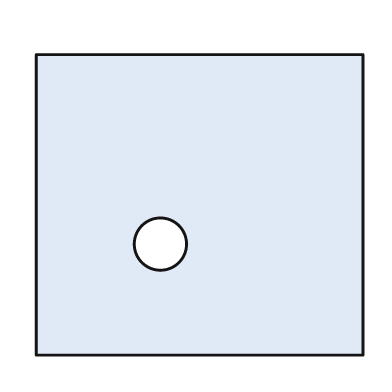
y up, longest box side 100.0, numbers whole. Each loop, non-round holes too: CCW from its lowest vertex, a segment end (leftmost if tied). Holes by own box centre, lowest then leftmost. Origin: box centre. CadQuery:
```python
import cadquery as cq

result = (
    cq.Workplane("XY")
    .moveTo(-50.0, -46.0)
    .lineTo(50.0, -46.0)
    .lineTo(50.0, 46.0)
    .lineTo(-50.0, 46.0)
    .close()
    .moveTo(-12.0, -12.0)
    .circle(8.0)
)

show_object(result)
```